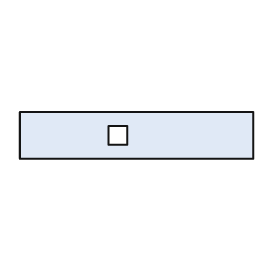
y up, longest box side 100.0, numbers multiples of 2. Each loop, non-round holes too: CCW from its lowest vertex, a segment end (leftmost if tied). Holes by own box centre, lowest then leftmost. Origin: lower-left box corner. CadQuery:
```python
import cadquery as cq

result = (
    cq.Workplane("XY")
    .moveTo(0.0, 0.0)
    .lineTo(100.0, 0.0)
    .lineTo(100.0, 20.0)
    .lineTo(0.0, 20.0)
    .close()
    .moveTo(38.0, 6.0)
    .lineTo(46.0, 6.0)
    .lineTo(46.0, 14.0)
    .lineTo(38.0, 14.0)
    .close()
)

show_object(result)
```